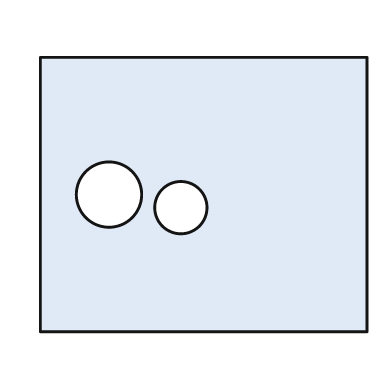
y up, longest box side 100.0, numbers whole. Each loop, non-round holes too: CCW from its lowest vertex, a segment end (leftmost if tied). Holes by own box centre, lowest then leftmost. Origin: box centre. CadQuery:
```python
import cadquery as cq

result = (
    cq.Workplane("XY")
    .moveTo(-50.0, -42.0)
    .lineTo(50.0, -42.0)
    .lineTo(50.0, 42.0)
    .lineTo(-50.0, 42.0)
    .close()
    .moveTo(-7.0, -4.0)
    .circle(8.0)
    .moveTo(-29.0, 0.0)
    .circle(10.0)
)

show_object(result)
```